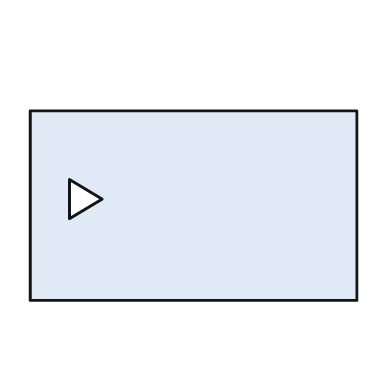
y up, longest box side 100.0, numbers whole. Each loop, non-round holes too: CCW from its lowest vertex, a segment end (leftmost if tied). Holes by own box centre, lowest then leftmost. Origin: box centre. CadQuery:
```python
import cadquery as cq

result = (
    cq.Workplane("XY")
    .moveTo(-50.0, -29.0)
    .lineTo(50.0, -29.0)
    .lineTo(50.0, 29.0)
    .lineTo(-50.0, 29.0)
    .close()
    .moveTo(-38.0, -4.0)
    .lineTo(-28.0, 2.0)
    .lineTo(-38.0, 8.0)
    .close()
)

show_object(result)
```